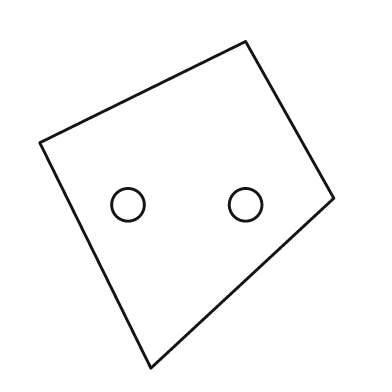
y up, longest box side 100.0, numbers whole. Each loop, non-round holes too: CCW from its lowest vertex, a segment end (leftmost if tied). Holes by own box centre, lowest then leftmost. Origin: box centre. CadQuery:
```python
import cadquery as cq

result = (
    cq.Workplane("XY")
    .moveTo(-11.0, -50.0)
    .lineTo(45.0, 2.0)
    .lineTo(18.0, 50.0)
    .lineTo(-45.0, 19.0)
    .close()
    .moveTo(-18.0, 0.0)
    .circle(5.0)
    .moveTo(18.0, 0.0)
    .circle(5.0)
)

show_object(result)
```